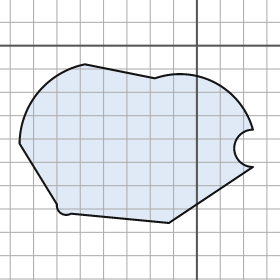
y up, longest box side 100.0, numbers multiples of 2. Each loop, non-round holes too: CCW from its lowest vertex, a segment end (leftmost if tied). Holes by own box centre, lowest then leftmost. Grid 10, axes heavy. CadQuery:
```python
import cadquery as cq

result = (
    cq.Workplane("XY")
    .moveTo(-12.0, -76.0)
    .lineTo(24.0, -52.0)
    .threePointArc((16.0, -44.0), (24.0, -36.0))
    .threePointArc((8.0, -16.0), (-18.0, -14.0))
    .lineTo(-48.0, -8.0)
    .threePointArc((-68.0, -20.0), (-76.0, -42.0))
    .lineTo(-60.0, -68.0)
    .threePointArc((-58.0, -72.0), (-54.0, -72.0))
    .close()
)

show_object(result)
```